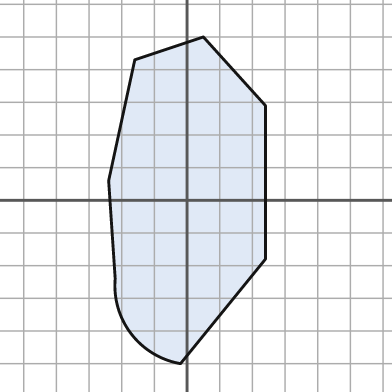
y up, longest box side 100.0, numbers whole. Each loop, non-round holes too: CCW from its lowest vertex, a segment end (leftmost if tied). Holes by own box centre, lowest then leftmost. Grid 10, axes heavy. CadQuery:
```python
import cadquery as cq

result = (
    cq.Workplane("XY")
    .moveTo(-2.0, -50.0)
    .lineTo(24.0, -18.0)
    .lineTo(24.0, 29.0)
    .lineTo(5.0, 50.0)
    .lineTo(-16.0, 43.0)
    .lineTo(-24.0, 6.0)
    .lineTo(-22.0, -24.0)
    .threePointArc((-17.0, -41.0), (-2.0, -50.0))
    .close()
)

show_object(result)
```